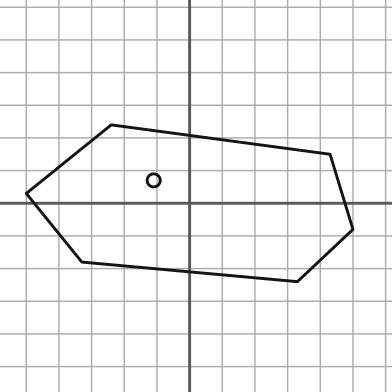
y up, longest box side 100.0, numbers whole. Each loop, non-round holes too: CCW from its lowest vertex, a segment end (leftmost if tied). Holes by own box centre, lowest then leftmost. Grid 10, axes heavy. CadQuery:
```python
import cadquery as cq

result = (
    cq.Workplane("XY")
    .moveTo(33.0, -24.0)
    .lineTo(50.0, -8.0)
    .lineTo(43.0, 15.0)
    .lineTo(-24.0, 24.0)
    .lineTo(-50.0, 3.0)
    .lineTo(-33.0, -18.0)
    .close()
    .moveTo(-11.0, 7.0)
    .circle(2.0)
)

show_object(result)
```